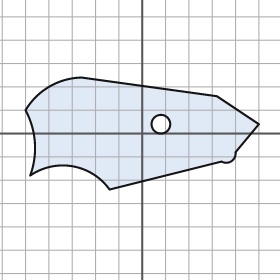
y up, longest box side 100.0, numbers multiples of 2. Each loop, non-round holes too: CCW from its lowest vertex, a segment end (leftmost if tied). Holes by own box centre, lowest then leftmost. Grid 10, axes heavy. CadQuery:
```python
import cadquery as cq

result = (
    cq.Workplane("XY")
    .moveTo(-14.0, -24.0)
    .lineTo(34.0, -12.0)
    .threePointArc((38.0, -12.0), (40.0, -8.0))
    .lineTo(50.0, 4.0)
    .lineTo(32.0, 16.0)
    .lineTo(-26.0, 24.0)
    .threePointArc((-40.0, 20.0), (-50.0, 10.0))
    .threePointArc((-46.0, -4.0), (-48.0, -18.0))
    .threePointArc((-30.0, -14.0), (-14.0, -24.0))
    .close()
    .moveTo(8.0, 4.0)
    .circle(4.0)
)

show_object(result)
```